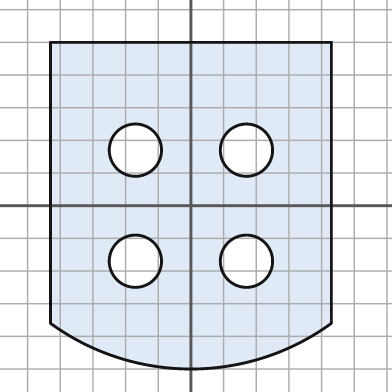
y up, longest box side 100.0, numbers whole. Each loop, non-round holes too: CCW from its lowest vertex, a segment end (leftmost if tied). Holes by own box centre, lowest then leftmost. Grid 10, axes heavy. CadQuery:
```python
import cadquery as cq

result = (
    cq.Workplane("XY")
    .moveTo(-43.0, -36.0)
    .threePointArc((0.0, -50.0), (43.0, -36.0))
    .lineTo(43.0, 50.0)
    .lineTo(-43.0, 50.0)
    .close()
    .moveTo(-17.0, -17.0)
    .circle(8.0)
    .moveTo(17.0, -17.0)
    .circle(8.0)
    .moveTo(-17.0, 17.0)
    .circle(8.0)
    .moveTo(17.0, 17.0)
    .circle(8.0)
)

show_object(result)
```